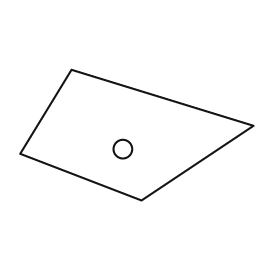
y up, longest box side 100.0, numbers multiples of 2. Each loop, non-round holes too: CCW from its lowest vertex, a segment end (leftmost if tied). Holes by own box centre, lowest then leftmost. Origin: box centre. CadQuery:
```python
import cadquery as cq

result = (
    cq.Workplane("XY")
    .moveTo(2.0, -28.0)
    .lineTo(50.0, 4.0)
    .lineTo(-28.0, 28.0)
    .lineTo(-50.0, -8.0)
    .close()
    .moveTo(-6.0, -6.0)
    .circle(4.0)
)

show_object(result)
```